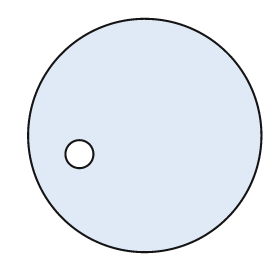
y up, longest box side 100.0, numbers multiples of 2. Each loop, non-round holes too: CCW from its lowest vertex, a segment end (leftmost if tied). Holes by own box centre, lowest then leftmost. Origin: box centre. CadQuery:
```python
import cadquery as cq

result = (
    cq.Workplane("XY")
    .moveTo(0.0, 0.0)
    .circle(50.0)
    .moveTo(-28.0, -8.0)
    .circle(6.0)
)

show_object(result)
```